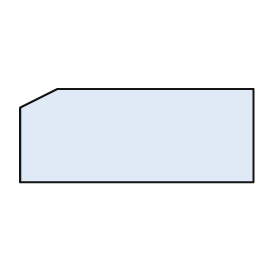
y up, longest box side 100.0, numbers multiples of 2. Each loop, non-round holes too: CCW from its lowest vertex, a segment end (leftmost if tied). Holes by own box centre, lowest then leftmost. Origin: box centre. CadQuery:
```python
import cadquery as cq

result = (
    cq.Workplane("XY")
    .moveTo(-50.0, -20.0)
    .lineTo(50.0, -20.0)
    .lineTo(50.0, 20.0)
    .lineTo(-34.0, 20.0)
    .lineTo(-50.0, 12.0)
    .close()
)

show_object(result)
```